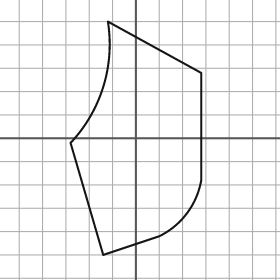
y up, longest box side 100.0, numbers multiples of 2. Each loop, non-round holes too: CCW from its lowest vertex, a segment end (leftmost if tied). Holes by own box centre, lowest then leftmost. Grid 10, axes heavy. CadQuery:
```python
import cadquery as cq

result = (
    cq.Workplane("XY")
    .moveTo(-14.0, -50.0)
    .lineTo(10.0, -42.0)
    .threePointArc((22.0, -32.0), (28.0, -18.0))
    .lineTo(28.0, 28.0)
    .lineTo(-12.0, 50.0)
    .threePointArc((-14.0, 22.0), (-28.0, -2.0))
    .close()
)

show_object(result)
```